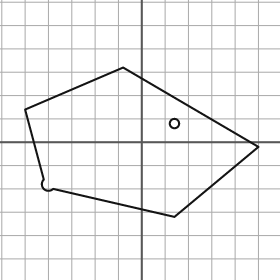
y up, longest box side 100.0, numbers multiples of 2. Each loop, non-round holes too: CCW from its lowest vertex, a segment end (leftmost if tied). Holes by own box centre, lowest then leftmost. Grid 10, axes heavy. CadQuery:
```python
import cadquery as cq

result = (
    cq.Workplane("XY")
    .moveTo(14.0, -32.0)
    .lineTo(50.0, -2.0)
    .lineTo(-8.0, 32.0)
    .lineTo(-50.0, 14.0)
    .lineTo(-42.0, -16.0)
    .threePointArc((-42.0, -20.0), (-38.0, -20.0))
    .close()
    .moveTo(14.0, 8.0)
    .circle(2.0)
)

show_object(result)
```